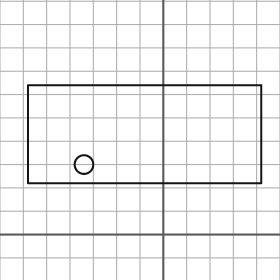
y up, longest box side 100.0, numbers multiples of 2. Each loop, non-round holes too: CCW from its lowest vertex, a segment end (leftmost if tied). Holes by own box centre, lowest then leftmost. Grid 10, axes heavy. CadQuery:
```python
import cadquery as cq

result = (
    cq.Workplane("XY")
    .moveTo(-58.0, 22.0)
    .lineTo(42.0, 22.0)
    .lineTo(42.0, 64.0)
    .lineTo(-58.0, 64.0)
    .close()
    .moveTo(-34.0, 30.0)
    .circle(4.0)
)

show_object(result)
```